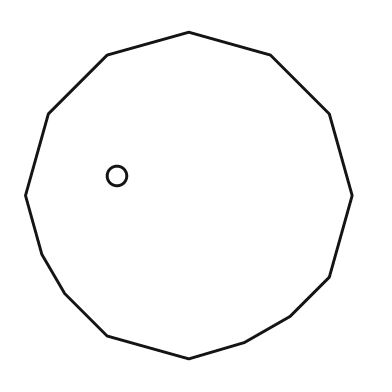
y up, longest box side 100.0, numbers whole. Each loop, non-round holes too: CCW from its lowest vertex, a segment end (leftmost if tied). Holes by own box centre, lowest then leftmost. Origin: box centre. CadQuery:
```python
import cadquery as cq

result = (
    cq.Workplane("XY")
    .moveTo(0.0, -50.0)
    .lineTo(17.0, -45.0)
    .lineTo(31.0, -37.0)
    .lineTo(43.0, -25.0)
    .lineTo(50.0, 0.0)
    .lineTo(43.0, 25.0)
    .lineTo(25.0, 43.0)
    .lineTo(0.0, 50.0)
    .lineTo(-25.0, 43.0)
    .lineTo(-43.0, 25.0)
    .lineTo(-50.0, 0.0)
    .lineTo(-45.0, -18.0)
    .lineTo(-38.0, -30.0)
    .lineTo(-25.0, -43.0)
    .close()
    .moveTo(-22.0, 6.0)
    .circle(3.0)
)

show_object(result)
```